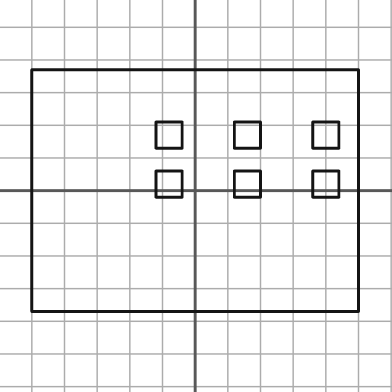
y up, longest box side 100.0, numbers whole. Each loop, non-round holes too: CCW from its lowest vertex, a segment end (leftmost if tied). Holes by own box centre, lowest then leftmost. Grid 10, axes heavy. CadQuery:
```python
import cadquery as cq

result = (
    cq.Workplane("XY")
    .moveTo(-50.0, -37.0)
    .lineTo(50.0, -37.0)
    .lineTo(50.0, 37.0)
    .lineTo(-50.0, 37.0)
    .close()
    .moveTo(-12.0, -2.0)
    .lineTo(-4.0, -2.0)
    .lineTo(-4.0, 6.0)
    .lineTo(-12.0, 6.0)
    .close()
    .moveTo(12.0, -2.0)
    .lineTo(20.0, -2.0)
    .lineTo(20.0, 6.0)
    .lineTo(12.0, 6.0)
    .close()
    .moveTo(36.0, -2.0)
    .lineTo(44.0, -2.0)
    .lineTo(44.0, 6.0)
    .lineTo(36.0, 6.0)
    .close()
    .moveTo(-12.0, 13.0)
    .lineTo(-4.0, 13.0)
    .lineTo(-4.0, 21.0)
    .lineTo(-12.0, 21.0)
    .close()
    .moveTo(12.0, 13.0)
    .lineTo(20.0, 13.0)
    .lineTo(20.0, 21.0)
    .lineTo(12.0, 21.0)
    .close()
    .moveTo(36.0, 13.0)
    .lineTo(44.0, 13.0)
    .lineTo(44.0, 21.0)
    .lineTo(36.0, 21.0)
    .close()
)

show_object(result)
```